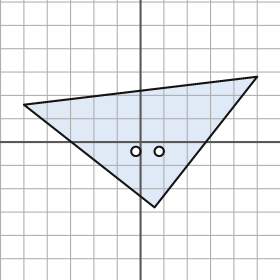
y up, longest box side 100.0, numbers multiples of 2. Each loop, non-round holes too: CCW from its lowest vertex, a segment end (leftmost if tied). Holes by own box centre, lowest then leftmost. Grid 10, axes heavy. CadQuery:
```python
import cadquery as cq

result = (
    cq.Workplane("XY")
    .moveTo(6.0, -28.0)
    .lineTo(50.0, 28.0)
    .lineTo(-50.0, 16.0)
    .close()
    .moveTo(-2.0, -4.0)
    .circle(2.0)
    .moveTo(8.0, -4.0)
    .circle(2.0)
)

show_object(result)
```